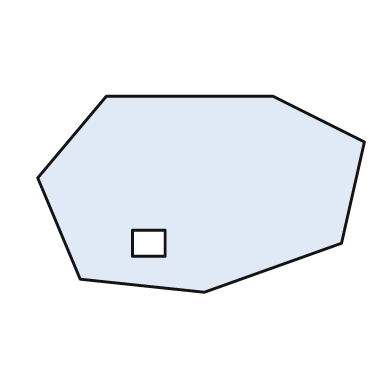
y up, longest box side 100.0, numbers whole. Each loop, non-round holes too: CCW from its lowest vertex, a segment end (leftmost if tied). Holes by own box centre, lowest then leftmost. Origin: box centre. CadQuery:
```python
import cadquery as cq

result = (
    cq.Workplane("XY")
    .moveTo(1.0, -30.0)
    .lineTo(43.0, -15.0)
    .lineTo(50.0, 16.0)
    .lineTo(22.0, 30.0)
    .lineTo(-29.0, 30.0)
    .lineTo(-50.0, 5.0)
    .lineTo(-37.0, -26.0)
    .close()
    .moveTo(-21.0, -19.0)
    .lineTo(-11.0, -19.0)
    .lineTo(-11.0, -11.0)
    .lineTo(-21.0, -11.0)
    .close()
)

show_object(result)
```